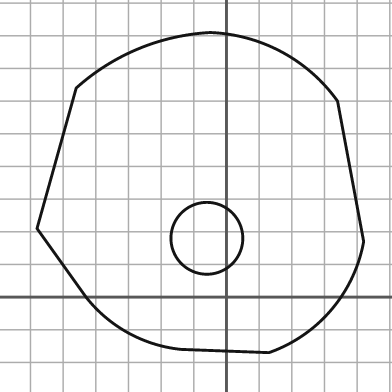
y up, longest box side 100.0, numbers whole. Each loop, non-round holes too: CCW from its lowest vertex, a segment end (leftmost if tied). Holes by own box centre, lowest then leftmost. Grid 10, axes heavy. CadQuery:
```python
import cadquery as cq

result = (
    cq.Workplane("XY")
    .moveTo(13.0, -17.0)
    .threePointArc((32.0, -4.0), (42.0, 17.0))
    .lineTo(34.0, 60.0)
    .threePointArc((17.0, 75.0), (-5.0, 81.0))
    .threePointArc((-27.0, 76.0), (-46.0, 64.0))
    .lineTo(-58.0, 21.0)
    .lineTo(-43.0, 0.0)
    .threePointArc((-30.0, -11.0), (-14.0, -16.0))
    .close()
    .moveTo(-6.0, 18.0)
    .circle(11.0)
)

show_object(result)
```